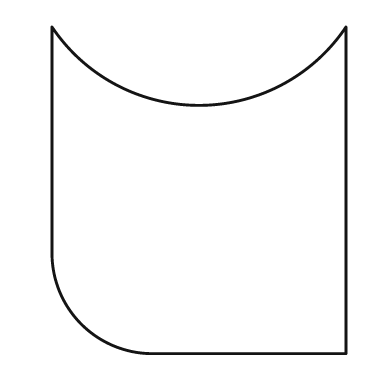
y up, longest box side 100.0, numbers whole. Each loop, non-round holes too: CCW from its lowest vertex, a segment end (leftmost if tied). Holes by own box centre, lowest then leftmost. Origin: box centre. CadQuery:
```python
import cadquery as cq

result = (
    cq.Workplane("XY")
    .moveTo(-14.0, -50.0)
    .lineTo(45.0, -50.0)
    .lineTo(45.0, 50.0)
    .threePointArc((0.0, 26.0), (-45.0, 50.0))
    .lineTo(-45.0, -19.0)
    .threePointArc((-36.0, -41.0), (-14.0, -50.0))
    .close()
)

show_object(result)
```